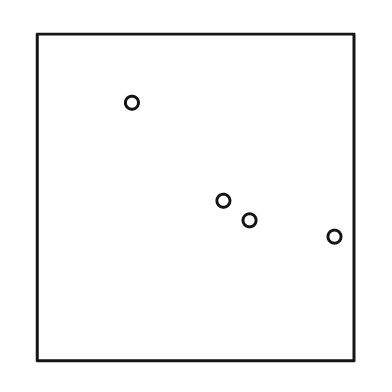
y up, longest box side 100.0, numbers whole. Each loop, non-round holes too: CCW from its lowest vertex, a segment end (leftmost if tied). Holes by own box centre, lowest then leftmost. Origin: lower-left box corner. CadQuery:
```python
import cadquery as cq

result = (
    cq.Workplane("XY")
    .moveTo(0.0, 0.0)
    .lineTo(97.0, 0.0)
    .lineTo(97.0, 100.0)
    .lineTo(0.0, 100.0)
    .close()
    .moveTo(91.0, 38.0)
    .circle(2.0)
    .moveTo(65.0, 43.0)
    .circle(2.0)
    .moveTo(57.0, 49.0)
    .circle(2.0)
    .moveTo(29.0, 79.0)
    .circle(2.0)
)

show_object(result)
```